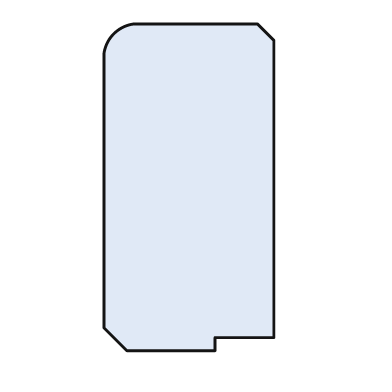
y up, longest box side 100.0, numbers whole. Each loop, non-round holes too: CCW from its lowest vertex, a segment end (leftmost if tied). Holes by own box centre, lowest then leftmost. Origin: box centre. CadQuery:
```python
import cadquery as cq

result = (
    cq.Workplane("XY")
    .moveTo(-19.0, -50.0)
    .lineTo(8.0, -50.0)
    .lineTo(8.0, -46.0)
    .lineTo(26.0, -46.0)
    .lineTo(26.0, 45.0)
    .lineTo(21.0, 50.0)
    .lineTo(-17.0, 50.0)
    .threePointArc((-23.0, 47.0), (-26.0, 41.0))
    .lineTo(-26.0, -43.0)
    .close()
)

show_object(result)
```